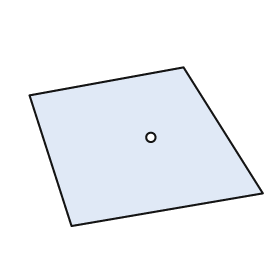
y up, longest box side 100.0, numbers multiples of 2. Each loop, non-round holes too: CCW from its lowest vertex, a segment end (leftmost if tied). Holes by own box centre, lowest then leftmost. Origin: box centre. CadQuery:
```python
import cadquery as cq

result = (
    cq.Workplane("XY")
    .moveTo(-32.0, -34.0)
    .lineTo(50.0, -20.0)
    .lineTo(16.0, 34.0)
    .lineTo(-50.0, 22.0)
    .close()
    .moveTo(2.0, 4.0)
    .circle(2.0)
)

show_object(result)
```